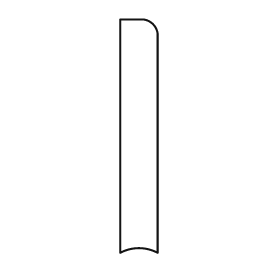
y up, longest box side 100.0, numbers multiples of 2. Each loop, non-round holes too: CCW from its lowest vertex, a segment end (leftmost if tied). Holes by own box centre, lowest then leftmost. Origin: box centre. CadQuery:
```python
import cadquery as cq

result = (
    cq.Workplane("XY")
    .moveTo(-8.0, -50.0)
    .threePointArc((0.0, -48.0), (8.0, -50.0))
    .lineTo(8.0, 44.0)
    .threePointArc((6.0, 48.0), (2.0, 50.0))
    .lineTo(-8.0, 50.0)
    .close()
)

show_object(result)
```